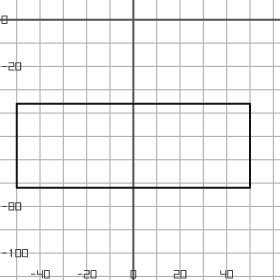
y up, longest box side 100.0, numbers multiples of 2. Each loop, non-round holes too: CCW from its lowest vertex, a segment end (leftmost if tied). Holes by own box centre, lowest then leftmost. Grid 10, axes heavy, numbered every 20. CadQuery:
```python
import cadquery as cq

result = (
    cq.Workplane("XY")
    .moveTo(-50.0, -72.0)
    .lineTo(50.0, -72.0)
    .lineTo(50.0, -36.0)
    .lineTo(-50.0, -36.0)
    .close()
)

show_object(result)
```